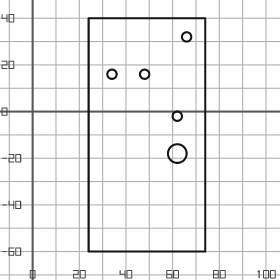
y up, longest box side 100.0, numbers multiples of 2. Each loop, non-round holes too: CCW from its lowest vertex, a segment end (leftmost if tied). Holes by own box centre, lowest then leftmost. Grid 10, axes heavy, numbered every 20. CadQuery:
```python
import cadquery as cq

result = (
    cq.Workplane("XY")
    .moveTo(24.0, -60.0)
    .lineTo(74.0, -60.0)
    .lineTo(74.0, 40.0)
    .lineTo(24.0, 40.0)
    .close()
    .moveTo(62.0, -18.0)
    .circle(4.0)
    .moveTo(62.0, -2.0)
    .circle(2.0)
    .moveTo(34.0, 16.0)
    .circle(2.0)
    .moveTo(48.0, 16.0)
    .circle(2.0)
    .moveTo(66.0, 32.0)
    .circle(2.0)
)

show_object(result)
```